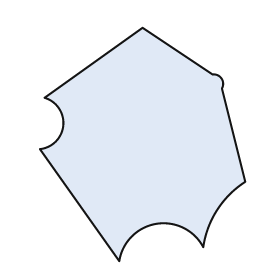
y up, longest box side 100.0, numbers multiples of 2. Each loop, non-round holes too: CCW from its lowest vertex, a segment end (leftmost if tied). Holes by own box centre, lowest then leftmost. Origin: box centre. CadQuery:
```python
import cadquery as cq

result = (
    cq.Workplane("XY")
    .moveTo(-10.0, -50.0)
    .threePointArc((6.0, -34.0), (26.0, -44.0))
    .threePointArc((32.0, -28.0), (44.0, -16.0))
    .lineTo(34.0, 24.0)
    .threePointArc((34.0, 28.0), (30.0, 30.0))
    .lineTo(0.0, 50.0)
    .lineTo(-42.0, 20.0)
    .threePointArc((-34.0, 8.0), (-44.0, -2.0))
    .close()
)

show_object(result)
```